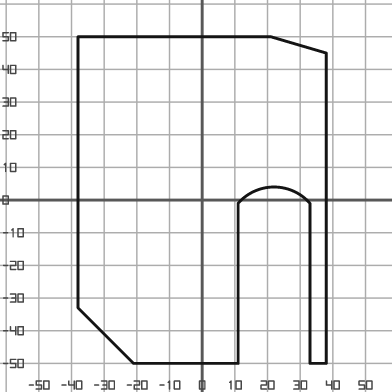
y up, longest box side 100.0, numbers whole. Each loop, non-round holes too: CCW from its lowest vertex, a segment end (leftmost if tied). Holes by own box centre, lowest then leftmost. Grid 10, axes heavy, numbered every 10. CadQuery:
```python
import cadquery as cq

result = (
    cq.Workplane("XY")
    .moveTo(-21.0, -50.0)
    .lineTo(11.0, -50.0)
    .lineTo(11.0, -1.0)
    .threePointArc((22.0, 4.0), (33.0, -1.0))
    .lineTo(33.0, -50.0)
    .lineTo(38.0, -50.0)
    .lineTo(38.0, 45.0)
    .lineTo(21.0, 50.0)
    .lineTo(-38.0, 50.0)
    .lineTo(-38.0, -33.0)
    .close()
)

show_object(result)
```